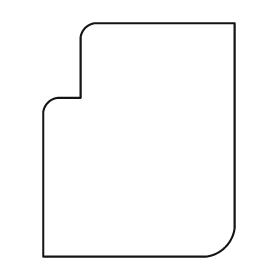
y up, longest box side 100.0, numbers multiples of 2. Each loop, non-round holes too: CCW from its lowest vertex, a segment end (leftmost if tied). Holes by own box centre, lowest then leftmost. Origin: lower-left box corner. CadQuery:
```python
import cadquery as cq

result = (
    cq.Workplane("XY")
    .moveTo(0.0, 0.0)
    .lineTo(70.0, 0.0)
    .threePointArc((78.0, 4.0), (82.0, 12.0))
    .lineTo(82.0, 100.0)
    .lineTo(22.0, 100.0)
    .threePointArc((18.0, 98.0), (16.0, 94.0))
    .lineTo(16.0, 68.0)
    .lineTo(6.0, 68.0)
    .threePointArc((2.0, 66.0), (0.0, 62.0))
    .close()
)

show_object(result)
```